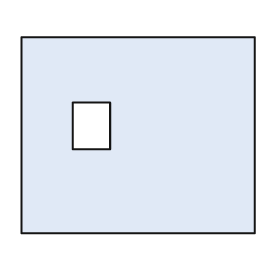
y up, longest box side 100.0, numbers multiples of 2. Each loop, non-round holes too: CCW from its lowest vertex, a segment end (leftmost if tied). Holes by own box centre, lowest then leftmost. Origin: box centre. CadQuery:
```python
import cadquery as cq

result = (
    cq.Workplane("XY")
    .moveTo(-50.0, -42.0)
    .lineTo(50.0, -42.0)
    .lineTo(50.0, 42.0)
    .lineTo(-50.0, 42.0)
    .close()
    .moveTo(-28.0, -6.0)
    .lineTo(-12.0, -6.0)
    .lineTo(-12.0, 14.0)
    .lineTo(-28.0, 14.0)
    .close()
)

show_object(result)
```